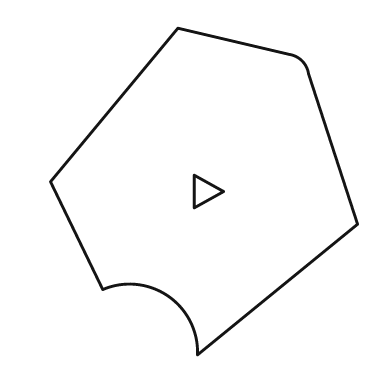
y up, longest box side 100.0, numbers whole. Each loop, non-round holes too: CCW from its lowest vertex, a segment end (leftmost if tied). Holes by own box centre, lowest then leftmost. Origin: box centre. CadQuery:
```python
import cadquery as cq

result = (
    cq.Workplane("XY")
    .moveTo(-2.0, -50.0)
    .lineTo(47.0, -10.0)
    .lineTo(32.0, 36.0)
    .threePointArc((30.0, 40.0), (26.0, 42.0))
    .lineTo(-8.0, 50.0)
    .lineTo(-47.0, 3.0)
    .lineTo(-31.0, -30.0)
    .threePointArc((-11.0, -32.0), (-2.0, -50.0))
    .close()
    .moveTo(-3.0, -5.0)
    .lineTo(6.0, 0.0)
    .lineTo(-3.0, 5.0)
    .close()
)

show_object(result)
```